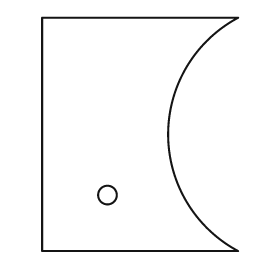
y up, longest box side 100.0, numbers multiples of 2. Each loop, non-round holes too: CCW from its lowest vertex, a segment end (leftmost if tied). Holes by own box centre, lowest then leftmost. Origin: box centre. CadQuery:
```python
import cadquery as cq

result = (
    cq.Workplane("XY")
    .moveTo(-42.0, -50.0)
    .lineTo(42.0, -50.0)
    .threePointArc((12.0, 0.0), (42.0, 50.0))
    .lineTo(-42.0, 50.0)
    .close()
    .moveTo(-14.0, -26.0)
    .circle(4.0)
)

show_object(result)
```